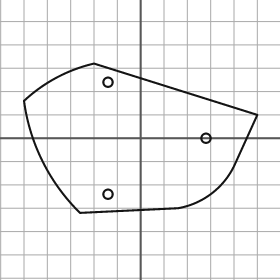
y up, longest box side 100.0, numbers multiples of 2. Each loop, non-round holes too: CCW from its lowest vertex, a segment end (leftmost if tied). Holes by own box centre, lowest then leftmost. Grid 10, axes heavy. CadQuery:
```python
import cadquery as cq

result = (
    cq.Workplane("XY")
    .moveTo(-26.0, -32.0)
    .lineTo(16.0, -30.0)
    .threePointArc((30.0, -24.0), (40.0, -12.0))
    .lineTo(50.0, 10.0)
    .lineTo(-20.0, 32.0)
    .threePointArc((-36.0, 26.0), (-50.0, 16.0))
    .threePointArc((-42.0, -10.0), (-26.0, -32.0))
    .close()
    .moveTo(-14.0, -24.0)
    .circle(2.0)
    .moveTo(28.0, 0.0)
    .circle(2.0)
    .moveTo(-14.0, 24.0)
    .circle(2.0)
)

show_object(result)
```